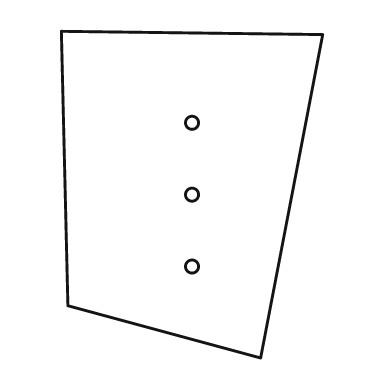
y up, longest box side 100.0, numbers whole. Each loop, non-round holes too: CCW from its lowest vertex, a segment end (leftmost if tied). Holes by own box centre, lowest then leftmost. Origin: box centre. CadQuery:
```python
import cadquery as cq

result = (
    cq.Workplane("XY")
    .moveTo(21.0, -50.0)
    .lineTo(40.0, 49.0)
    .lineTo(-40.0, 50.0)
    .lineTo(-38.0, -34.0)
    .close()
    .moveTo(0.0, -22.0)
    .circle(2.0)
    .moveTo(0.0, 0.0)
    .circle(2.0)
    .moveTo(0.0, 22.0)
    .circle(2.0)
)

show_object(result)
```